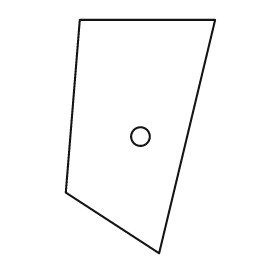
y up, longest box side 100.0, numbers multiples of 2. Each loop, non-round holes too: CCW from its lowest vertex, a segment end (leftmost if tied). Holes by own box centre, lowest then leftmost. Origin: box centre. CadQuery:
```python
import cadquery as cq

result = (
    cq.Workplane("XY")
    .moveTo(8.0, -50.0)
    .lineTo(32.0, 50.0)
    .lineTo(-26.0, 50.0)
    .lineTo(-32.0, -24.0)
    .close()
    .moveTo(0.0, 0.0)
    .circle(4.0)
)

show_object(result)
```